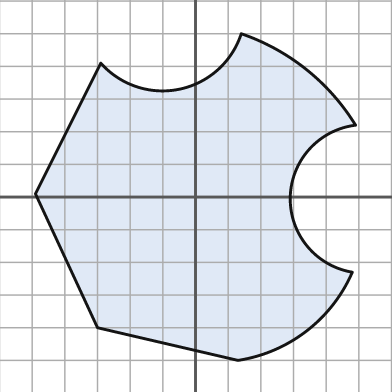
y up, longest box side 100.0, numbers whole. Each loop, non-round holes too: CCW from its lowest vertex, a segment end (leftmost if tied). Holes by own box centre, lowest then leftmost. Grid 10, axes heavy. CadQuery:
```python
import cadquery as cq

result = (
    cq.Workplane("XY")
    .moveTo(13.0, -50.0)
    .threePointArc((34.0, -41.0), (48.0, -23.0))
    .threePointArc((29.0, 0.0), (49.0, 22.0))
    .threePointArc((34.0, 39.0), (14.0, 50.0))
    .threePointArc((-5.0, 33.0), (-29.0, 41.0))
    .lineTo(-49.0, 1.0)
    .lineTo(-30.0, -40.0)
    .close()
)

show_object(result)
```